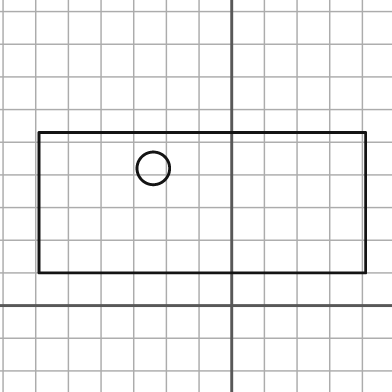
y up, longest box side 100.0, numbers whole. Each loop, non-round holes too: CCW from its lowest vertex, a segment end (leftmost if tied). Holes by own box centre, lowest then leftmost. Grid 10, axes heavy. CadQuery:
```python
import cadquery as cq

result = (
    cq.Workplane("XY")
    .moveTo(-59.0, 10.0)
    .lineTo(41.0, 10.0)
    .lineTo(41.0, 53.0)
    .lineTo(-59.0, 53.0)
    .close()
    .moveTo(-24.0, 42.0)
    .circle(5.0)
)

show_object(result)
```